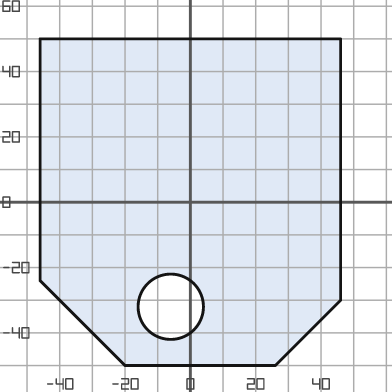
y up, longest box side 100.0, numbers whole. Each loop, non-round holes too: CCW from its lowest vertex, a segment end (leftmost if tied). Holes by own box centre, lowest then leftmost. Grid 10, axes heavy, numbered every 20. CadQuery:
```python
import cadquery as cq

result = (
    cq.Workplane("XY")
    .moveTo(-20.0, -50.0)
    .lineTo(26.0, -50.0)
    .lineTo(46.0, -30.0)
    .lineTo(46.0, 50.0)
    .lineTo(-46.0, 50.0)
    .lineTo(-46.0, -24.0)
    .close()
    .moveTo(-6.0, -32.0)
    .circle(10.0)
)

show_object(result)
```